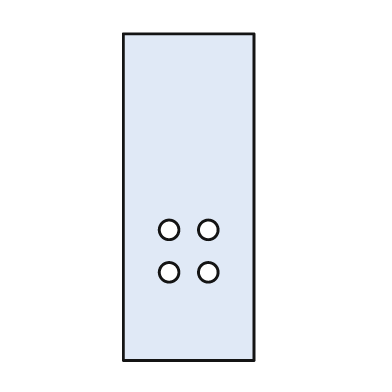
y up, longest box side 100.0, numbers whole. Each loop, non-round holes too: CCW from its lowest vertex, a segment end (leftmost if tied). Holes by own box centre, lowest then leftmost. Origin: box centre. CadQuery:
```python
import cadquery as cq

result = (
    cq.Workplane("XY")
    .moveTo(-20.0, -50.0)
    .lineTo(20.0, -50.0)
    .lineTo(20.0, 50.0)
    .lineTo(-20.0, 50.0)
    .close()
    .moveTo(-6.0, -23.0)
    .circle(3.0)
    .moveTo(6.0, -23.0)
    .circle(3.0)
    .moveTo(-6.0, -10.0)
    .circle(3.0)
    .moveTo(6.0, -10.0)
    .circle(3.0)
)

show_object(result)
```